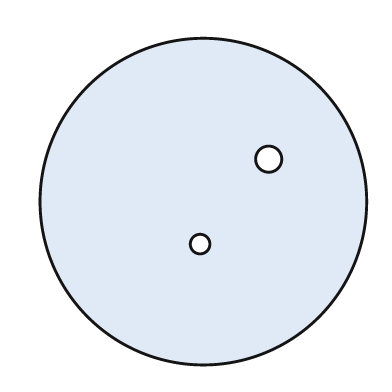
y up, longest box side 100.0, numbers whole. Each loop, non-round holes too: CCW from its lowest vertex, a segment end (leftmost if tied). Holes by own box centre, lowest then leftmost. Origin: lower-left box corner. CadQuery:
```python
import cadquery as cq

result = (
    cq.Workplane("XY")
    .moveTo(50.0, 50.0)
    .circle(50.0)
    .moveTo(49.0, 37.0)
    .circle(3.0)
    .moveTo(70.0, 63.0)
    .circle(4.0)
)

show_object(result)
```